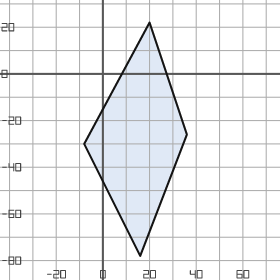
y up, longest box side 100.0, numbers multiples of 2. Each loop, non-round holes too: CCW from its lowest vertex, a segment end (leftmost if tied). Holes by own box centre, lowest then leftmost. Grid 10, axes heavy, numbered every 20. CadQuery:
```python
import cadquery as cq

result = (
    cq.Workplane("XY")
    .moveTo(16.0, -78.0)
    .lineTo(36.0, -26.0)
    .lineTo(20.0, 22.0)
    .lineTo(-8.0, -30.0)
    .close()
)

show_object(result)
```